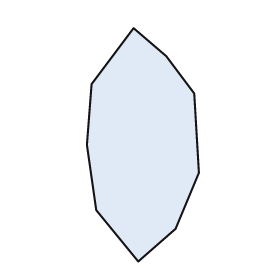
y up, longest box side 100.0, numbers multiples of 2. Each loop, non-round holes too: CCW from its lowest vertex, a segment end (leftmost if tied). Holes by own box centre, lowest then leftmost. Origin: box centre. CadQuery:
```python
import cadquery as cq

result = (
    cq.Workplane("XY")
    .moveTo(-2.0, -50.0)
    .lineTo(14.0, -36.0)
    .lineTo(24.0, -12.0)
    .lineTo(22.0, 22.0)
    .lineTo(10.0, 38.0)
    .lineTo(-4.0, 50.0)
    .lineTo(-22.0, 26.0)
    .lineTo(-24.0, 0.0)
    .lineTo(-20.0, -28.0)
    .close()
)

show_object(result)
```